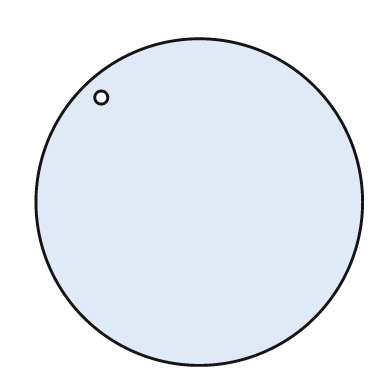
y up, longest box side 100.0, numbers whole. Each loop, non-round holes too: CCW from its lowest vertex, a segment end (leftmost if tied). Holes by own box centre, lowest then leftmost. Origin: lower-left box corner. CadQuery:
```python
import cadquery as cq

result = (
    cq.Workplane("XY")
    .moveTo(50.0, 50.0)
    .circle(50.0)
    .moveTo(20.0, 82.0)
    .circle(2.0)
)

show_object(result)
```